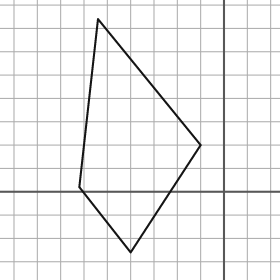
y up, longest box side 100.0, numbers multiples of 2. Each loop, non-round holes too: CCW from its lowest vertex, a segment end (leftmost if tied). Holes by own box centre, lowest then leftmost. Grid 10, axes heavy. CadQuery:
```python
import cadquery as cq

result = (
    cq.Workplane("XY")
    .moveTo(-40.0, -26.0)
    .lineTo(-10.0, 20.0)
    .lineTo(-54.0, 74.0)
    .lineTo(-62.0, 2.0)
    .close()
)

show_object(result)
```